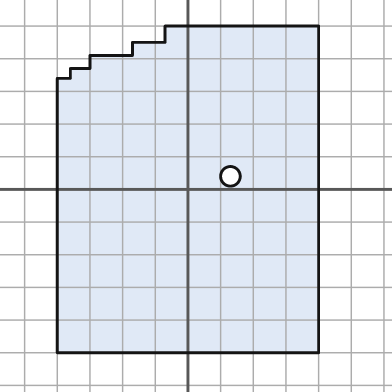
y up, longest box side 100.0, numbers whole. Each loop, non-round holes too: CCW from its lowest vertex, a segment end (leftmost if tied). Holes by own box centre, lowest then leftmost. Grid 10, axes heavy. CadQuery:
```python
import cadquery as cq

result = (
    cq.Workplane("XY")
    .moveTo(-40.0, -50.0)
    .lineTo(40.0, -50.0)
    .lineTo(40.0, 50.0)
    .lineTo(-7.0, 50.0)
    .lineTo(-7.0, 45.0)
    .lineTo(-17.0, 45.0)
    .lineTo(-17.0, 41.0)
    .lineTo(-30.0, 41.0)
    .lineTo(-30.0, 37.0)
    .lineTo(-36.0, 37.0)
    .lineTo(-36.0, 34.0)
    .lineTo(-40.0, 34.0)
    .close()
    .moveTo(13.0, 4.0)
    .circle(3.0)
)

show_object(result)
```